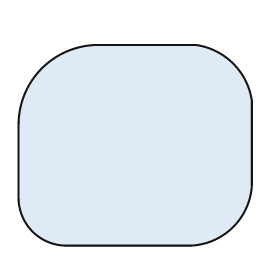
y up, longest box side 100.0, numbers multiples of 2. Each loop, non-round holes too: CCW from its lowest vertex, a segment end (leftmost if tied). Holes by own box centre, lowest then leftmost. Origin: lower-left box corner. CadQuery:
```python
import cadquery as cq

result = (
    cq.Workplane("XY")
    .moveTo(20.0, 0.0)
    .lineTo(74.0, 0.0)
    .threePointArc((92.0, 8.0), (100.0, 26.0))
    .lineTo(100.0, 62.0)
    .threePointArc((92.0, 78.0), (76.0, 86.0))
    .lineTo(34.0, 86.0)
    .threePointArc((10.0, 76.0), (0.0, 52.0))
    .lineTo(0.0, 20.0)
    .threePointArc((6.0, 6.0), (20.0, 0.0))
    .close()
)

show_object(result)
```